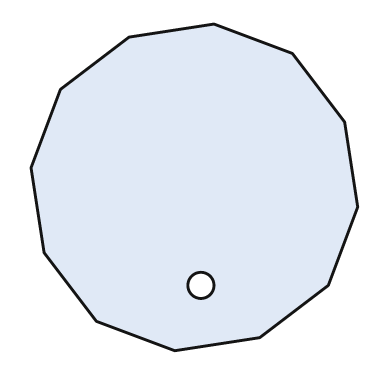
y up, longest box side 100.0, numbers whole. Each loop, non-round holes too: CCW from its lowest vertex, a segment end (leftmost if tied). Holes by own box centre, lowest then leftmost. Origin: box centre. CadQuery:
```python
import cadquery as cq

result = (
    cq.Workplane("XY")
    .moveTo(-6.0, -50.0)
    .lineTo(20.0, -46.0)
    .lineTo(41.0, -30.0)
    .lineTo(50.0, -6.0)
    .lineTo(46.0, 20.0)
    .lineTo(30.0, 41.0)
    .lineTo(6.0, 50.0)
    .lineTo(-20.0, 46.0)
    .lineTo(-41.0, 30.0)
    .lineTo(-50.0, 6.0)
    .lineTo(-46.0, -20.0)
    .lineTo(-30.0, -41.0)
    .close()
    .moveTo(2.0, -30.0)
    .circle(4.0)
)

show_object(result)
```